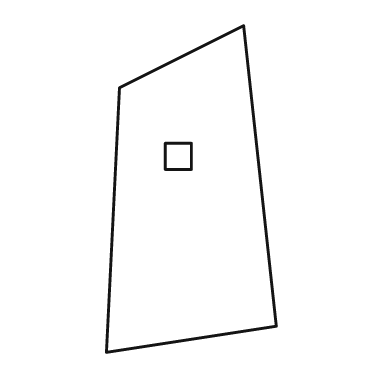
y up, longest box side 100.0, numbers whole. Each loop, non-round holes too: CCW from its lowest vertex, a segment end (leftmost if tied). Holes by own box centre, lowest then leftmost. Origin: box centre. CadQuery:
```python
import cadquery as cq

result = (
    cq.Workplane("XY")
    .moveTo(-26.0, -50.0)
    .lineTo(26.0, -42.0)
    .lineTo(16.0, 50.0)
    .lineTo(-22.0, 31.0)
    .close()
    .moveTo(-8.0, 6.0)
    .lineTo(0.0, 6.0)
    .lineTo(0.0, 14.0)
    .lineTo(-8.0, 14.0)
    .close()
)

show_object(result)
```